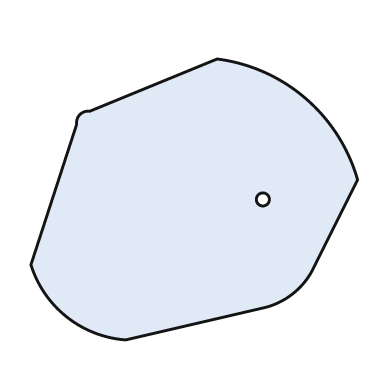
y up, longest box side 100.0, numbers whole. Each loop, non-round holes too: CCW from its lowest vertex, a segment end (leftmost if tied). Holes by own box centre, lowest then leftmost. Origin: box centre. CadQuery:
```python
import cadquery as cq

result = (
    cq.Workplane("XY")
    .moveTo(-21.0, -43.0)
    .lineTo(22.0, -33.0)
    .threePointArc((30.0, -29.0), (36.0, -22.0))
    .lineTo(50.0, 6.0)
    .threePointArc((34.0, 31.0), (7.0, 43.0))
    .lineTo(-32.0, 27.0)
    .threePointArc((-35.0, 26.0), (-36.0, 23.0))
    .lineTo(-50.0, -20.0)
    .threePointArc((-39.0, -36.0), (-21.0, -43.0))
    .close()
    .moveTo(21.0, 0.0)
    .circle(2.0)
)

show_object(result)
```